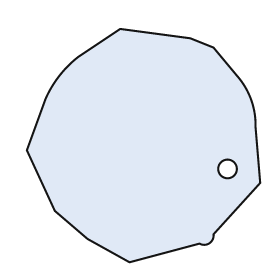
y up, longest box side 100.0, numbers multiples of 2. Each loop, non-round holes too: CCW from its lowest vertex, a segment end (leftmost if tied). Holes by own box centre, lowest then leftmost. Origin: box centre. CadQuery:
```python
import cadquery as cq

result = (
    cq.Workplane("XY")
    .moveTo(-6.0, -50.0)
    .lineTo(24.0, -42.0)
    .threePointArc((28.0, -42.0), (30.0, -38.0))
    .lineTo(50.0, -16.0)
    .lineTo(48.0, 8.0)
    .threePointArc((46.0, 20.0), (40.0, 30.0))
    .lineTo(30.0, 42.0)
    .lineTo(20.0, 46.0)
    .lineTo(-10.0, 50.0)
    .lineTo(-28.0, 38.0)
    .threePointArc((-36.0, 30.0), (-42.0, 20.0))
    .lineTo(-50.0, -2.0)
    .lineTo(-38.0, -28.0)
    .lineTo(-24.0, -40.0)
    .close()
    .moveTo(36.0, -10.0)
    .circle(4.0)
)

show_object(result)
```